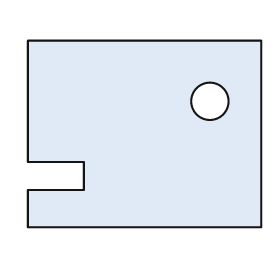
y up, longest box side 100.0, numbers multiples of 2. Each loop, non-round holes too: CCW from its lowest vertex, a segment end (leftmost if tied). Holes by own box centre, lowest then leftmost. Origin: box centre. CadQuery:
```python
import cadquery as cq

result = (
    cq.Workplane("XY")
    .moveTo(-50.0, -40.0)
    .lineTo(50.0, -40.0)
    .lineTo(50.0, 40.0)
    .lineTo(-50.0, 40.0)
    .lineTo(-50.0, -12.0)
    .lineTo(-26.0, -12.0)
    .lineTo(-26.0, -24.0)
    .lineTo(-50.0, -24.0)
    .close()
    .moveTo(28.0, 14.0)
    .circle(8.0)
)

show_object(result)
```